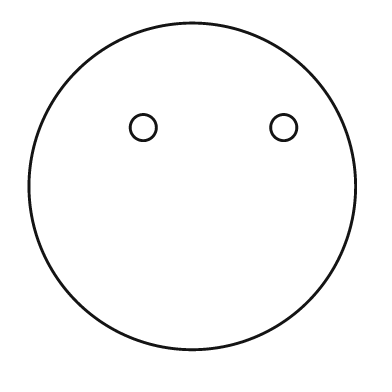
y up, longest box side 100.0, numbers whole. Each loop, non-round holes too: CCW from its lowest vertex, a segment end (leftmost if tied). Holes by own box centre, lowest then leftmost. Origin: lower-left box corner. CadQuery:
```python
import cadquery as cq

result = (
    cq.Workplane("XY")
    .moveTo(50.0, 50.0)
    .circle(50.0)
    .moveTo(35.0, 68.0)
    .circle(4.0)
    .moveTo(78.0, 68.0)
    .circle(4.0)
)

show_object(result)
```